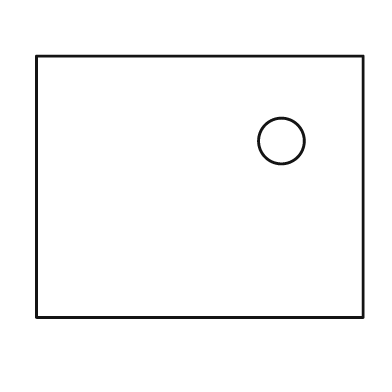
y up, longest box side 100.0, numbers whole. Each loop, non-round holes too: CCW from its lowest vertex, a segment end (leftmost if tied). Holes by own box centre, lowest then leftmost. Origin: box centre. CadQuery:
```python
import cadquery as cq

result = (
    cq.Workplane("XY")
    .moveTo(-50.0, -40.0)
    .lineTo(50.0, -40.0)
    .lineTo(50.0, 40.0)
    .lineTo(-50.0, 40.0)
    .close()
    .moveTo(25.0, 14.0)
    .circle(7.0)
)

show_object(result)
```